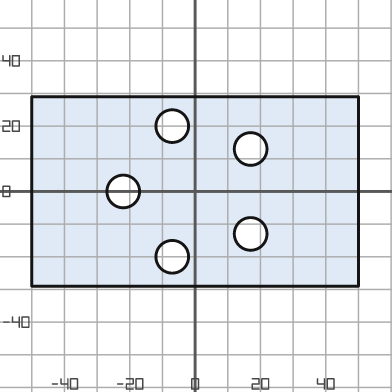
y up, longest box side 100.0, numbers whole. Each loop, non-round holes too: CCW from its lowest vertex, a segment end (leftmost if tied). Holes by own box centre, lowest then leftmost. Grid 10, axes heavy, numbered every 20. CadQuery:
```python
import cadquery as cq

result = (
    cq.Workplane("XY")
    .moveTo(-50.0, -29.0)
    .lineTo(50.0, -29.0)
    .lineTo(50.0, 29.0)
    .lineTo(-50.0, 29.0)
    .close()
    .moveTo(-7.0, -20.0)
    .circle(5.0)
    .moveTo(17.0, -13.0)
    .circle(5.0)
    .moveTo(-22.0, 0.0)
    .circle(5.0)
    .moveTo(17.0, 13.0)
    .circle(5.0)
    .moveTo(-7.0, 20.0)
    .circle(5.0)
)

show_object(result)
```